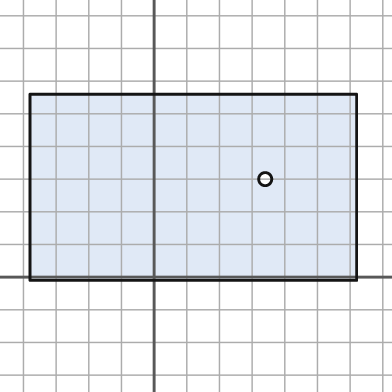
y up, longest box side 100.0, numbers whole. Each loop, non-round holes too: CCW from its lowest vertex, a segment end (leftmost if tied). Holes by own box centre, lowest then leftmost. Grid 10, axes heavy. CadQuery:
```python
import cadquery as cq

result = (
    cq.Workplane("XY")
    .moveTo(-38.0, -1.0)
    .lineTo(62.0, -1.0)
    .lineTo(62.0, 56.0)
    .lineTo(-38.0, 56.0)
    .close()
    .moveTo(34.0, 30.0)
    .circle(2.0)
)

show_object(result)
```